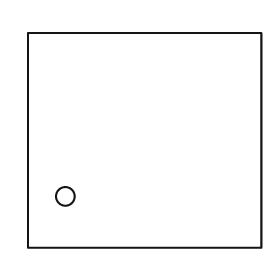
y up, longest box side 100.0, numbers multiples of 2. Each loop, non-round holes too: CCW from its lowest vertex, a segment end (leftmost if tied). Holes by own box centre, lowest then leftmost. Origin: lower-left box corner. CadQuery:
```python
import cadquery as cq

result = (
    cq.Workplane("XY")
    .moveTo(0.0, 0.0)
    .lineTo(100.0, 0.0)
    .lineTo(100.0, 92.0)
    .lineTo(0.0, 92.0)
    .close()
    .moveTo(16.0, 22.0)
    .circle(4.0)
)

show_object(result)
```